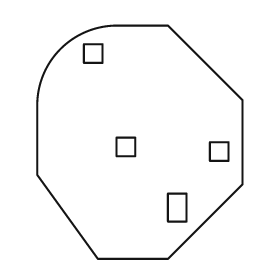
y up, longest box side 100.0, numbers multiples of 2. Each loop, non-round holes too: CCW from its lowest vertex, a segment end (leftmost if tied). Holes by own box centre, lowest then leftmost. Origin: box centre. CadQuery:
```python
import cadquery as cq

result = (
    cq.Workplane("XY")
    .moveTo(-18.0, -50.0)
    .lineTo(12.0, -50.0)
    .lineTo(44.0, -18.0)
    .lineTo(44.0, 18.0)
    .lineTo(12.0, 50.0)
    .lineTo(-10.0, 50.0)
    .threePointArc((-34.0, 40.0), (-44.0, 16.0))
    .lineTo(-44.0, -14.0)
    .close()
    .moveTo(12.0, -34.0)
    .lineTo(20.0, -34.0)
    .lineTo(20.0, -22.0)
    .lineTo(12.0, -22.0)
    .close()
    .moveTo(30.0, -8.0)
    .lineTo(38.0, -8.0)
    .lineTo(38.0, 0.0)
    .lineTo(30.0, 0.0)
    .close()
    .moveTo(-10.0, -6.0)
    .lineTo(-2.0, -6.0)
    .lineTo(-2.0, 2.0)
    .lineTo(-10.0, 2.0)
    .close()
    .moveTo(-24.0, 34.0)
    .lineTo(-16.0, 34.0)
    .lineTo(-16.0, 42.0)
    .lineTo(-24.0, 42.0)
    .close()
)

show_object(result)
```